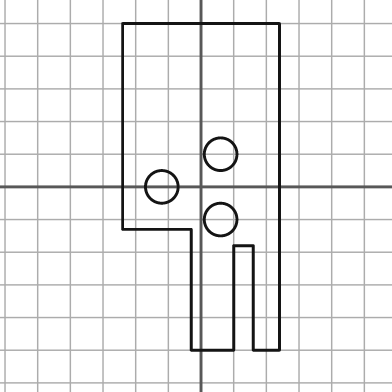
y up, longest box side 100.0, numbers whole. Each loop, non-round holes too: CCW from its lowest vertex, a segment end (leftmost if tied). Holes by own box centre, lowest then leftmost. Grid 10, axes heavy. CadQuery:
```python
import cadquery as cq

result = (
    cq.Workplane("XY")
    .moveTo(-3.0, -50.0)
    .lineTo(10.0, -50.0)
    .lineTo(10.0, -18.0)
    .lineTo(16.0, -18.0)
    .lineTo(16.0, -50.0)
    .lineTo(24.0, -50.0)
    .lineTo(24.0, 50.0)
    .lineTo(-24.0, 50.0)
    .lineTo(-24.0, -13.0)
    .lineTo(-3.0, -13.0)
    .close()
    .moveTo(6.0, -10.0)
    .circle(5.0)
    .moveTo(-12.0, 0.0)
    .circle(5.0)
    .moveTo(6.0, 10.0)
    .circle(5.0)
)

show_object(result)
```